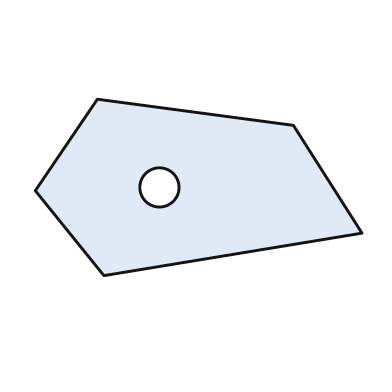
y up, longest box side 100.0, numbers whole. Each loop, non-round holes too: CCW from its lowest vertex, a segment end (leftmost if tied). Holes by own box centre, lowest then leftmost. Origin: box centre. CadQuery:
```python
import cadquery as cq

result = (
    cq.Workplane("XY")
    .moveTo(-29.0, -27.0)
    .lineTo(50.0, -14.0)
    .lineTo(29.0, 19.0)
    .lineTo(-31.0, 27.0)
    .lineTo(-50.0, -1.0)
    .close()
    .moveTo(-12.0, 0.0)
    .circle(6.0)
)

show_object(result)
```